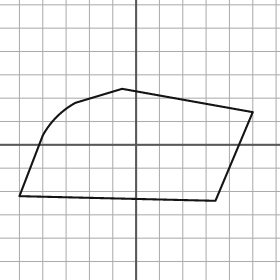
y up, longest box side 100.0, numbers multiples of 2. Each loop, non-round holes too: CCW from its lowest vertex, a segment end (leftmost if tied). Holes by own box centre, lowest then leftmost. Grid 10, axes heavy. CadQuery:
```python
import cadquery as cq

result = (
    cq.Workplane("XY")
    .moveTo(34.0, -24.0)
    .lineTo(50.0, 14.0)
    .lineTo(-6.0, 24.0)
    .lineTo(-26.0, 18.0)
    .threePointArc((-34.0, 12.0), (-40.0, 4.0))
    .lineTo(-50.0, -22.0)
    .close()
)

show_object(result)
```